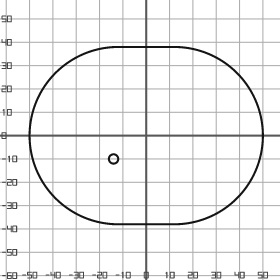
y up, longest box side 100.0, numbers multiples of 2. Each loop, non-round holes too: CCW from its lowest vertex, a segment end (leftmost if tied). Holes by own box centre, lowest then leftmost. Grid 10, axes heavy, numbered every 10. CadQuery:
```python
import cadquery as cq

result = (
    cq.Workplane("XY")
    .moveTo(-12.0, -38.0)
    .lineTo(12.0, -38.0)
    .threePointArc((50.0, 0.0), (12.0, 38.0))
    .lineTo(-12.0, 38.0)
    .threePointArc((-50.0, 0.0), (-12.0, -38.0))
    .close()
    .moveTo(-14.0, -10.0)
    .circle(2.0)
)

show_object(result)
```